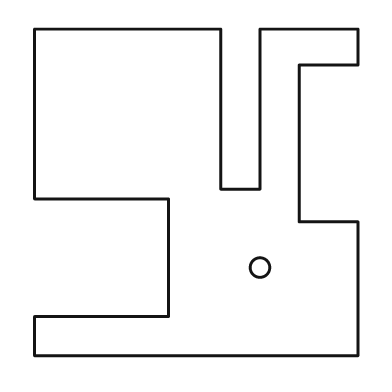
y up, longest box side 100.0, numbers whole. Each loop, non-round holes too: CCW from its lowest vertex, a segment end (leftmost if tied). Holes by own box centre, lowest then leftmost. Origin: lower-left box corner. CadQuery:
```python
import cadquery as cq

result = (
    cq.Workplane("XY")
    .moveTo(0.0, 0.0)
    .lineTo(99.0, 0.0)
    .lineTo(99.0, 41.0)
    .lineTo(81.0, 41.0)
    .lineTo(81.0, 89.0)
    .lineTo(99.0, 89.0)
    .lineTo(99.0, 100.0)
    .lineTo(69.0, 100.0)
    .lineTo(69.0, 51.0)
    .lineTo(57.0, 51.0)
    .lineTo(57.0, 100.0)
    .lineTo(0.0, 100.0)
    .lineTo(0.0, 48.0)
    .lineTo(41.0, 48.0)
    .lineTo(41.0, 12.0)
    .lineTo(0.0, 12.0)
    .close()
    .moveTo(69.0, 27.0)
    .circle(3.0)
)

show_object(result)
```